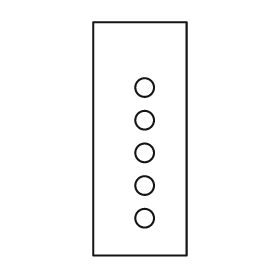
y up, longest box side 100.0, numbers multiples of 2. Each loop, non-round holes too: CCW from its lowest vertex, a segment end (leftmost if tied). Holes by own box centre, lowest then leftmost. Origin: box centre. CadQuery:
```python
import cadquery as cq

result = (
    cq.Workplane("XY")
    .moveTo(-20.0, -50.0)
    .lineTo(20.0, -50.0)
    .lineTo(20.0, 50.0)
    .lineTo(-20.0, 50.0)
    .close()
    .moveTo(2.0, -34.0)
    .circle(4.0)
    .moveTo(2.0, -20.0)
    .circle(4.0)
    .moveTo(2.0, -6.0)
    .circle(4.0)
    .moveTo(2.0, 8.0)
    .circle(4.0)
    .moveTo(2.0, 22.0)
    .circle(4.0)
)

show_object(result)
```